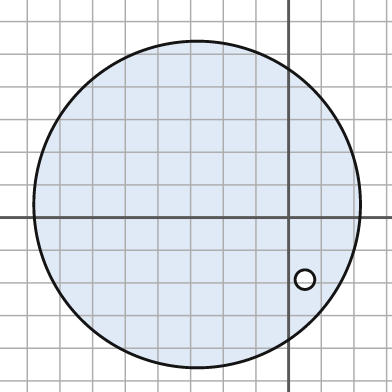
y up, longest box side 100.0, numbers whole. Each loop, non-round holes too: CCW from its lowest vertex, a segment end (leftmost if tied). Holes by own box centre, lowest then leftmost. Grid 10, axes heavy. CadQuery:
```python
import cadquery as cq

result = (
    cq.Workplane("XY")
    .moveTo(-28.0, 4.0)
    .circle(50.0)
    .moveTo(5.0, -19.0)
    .circle(3.0)
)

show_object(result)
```